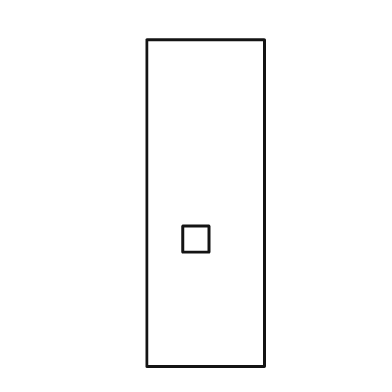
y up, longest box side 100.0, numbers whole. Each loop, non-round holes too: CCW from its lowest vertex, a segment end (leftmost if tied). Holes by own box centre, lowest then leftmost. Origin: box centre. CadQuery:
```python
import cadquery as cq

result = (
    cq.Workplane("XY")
    .moveTo(-18.0, -50.0)
    .lineTo(18.0, -50.0)
    .lineTo(18.0, 50.0)
    .lineTo(-18.0, 50.0)
    .close()
    .moveTo(-7.0, -15.0)
    .lineTo(1.0, -15.0)
    .lineTo(1.0, -7.0)
    .lineTo(-7.0, -7.0)
    .close()
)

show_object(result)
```